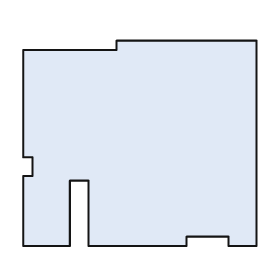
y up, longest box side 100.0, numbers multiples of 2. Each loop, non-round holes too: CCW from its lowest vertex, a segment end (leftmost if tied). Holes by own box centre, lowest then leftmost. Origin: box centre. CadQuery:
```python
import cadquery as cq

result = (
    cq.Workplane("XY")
    .moveTo(-50.0, -44.0)
    .lineTo(-30.0, -44.0)
    .lineTo(-30.0, -16.0)
    .lineTo(-22.0, -16.0)
    .lineTo(-22.0, -44.0)
    .lineTo(20.0, -44.0)
    .lineTo(20.0, -40.0)
    .lineTo(38.0, -40.0)
    .lineTo(38.0, -44.0)
    .lineTo(50.0, -44.0)
    .lineTo(50.0, 44.0)
    .lineTo(-10.0, 44.0)
    .lineTo(-10.0, 40.0)
    .lineTo(-50.0, 40.0)
    .lineTo(-50.0, -6.0)
    .lineTo(-46.0, -6.0)
    .lineTo(-46.0, -14.0)
    .lineTo(-50.0, -14.0)
    .close()
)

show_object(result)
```